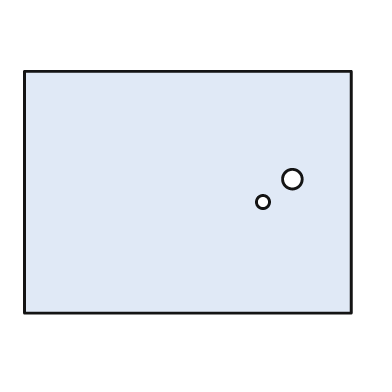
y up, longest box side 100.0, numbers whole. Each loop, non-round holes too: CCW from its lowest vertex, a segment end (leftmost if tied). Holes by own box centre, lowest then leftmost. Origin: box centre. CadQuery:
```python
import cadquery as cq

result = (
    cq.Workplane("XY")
    .moveTo(-50.0, -37.0)
    .lineTo(50.0, -37.0)
    .lineTo(50.0, 37.0)
    .lineTo(-50.0, 37.0)
    .close()
    .moveTo(23.0, -3.0)
    .circle(2.0)
    .moveTo(32.0, 4.0)
    .circle(3.0)
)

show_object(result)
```